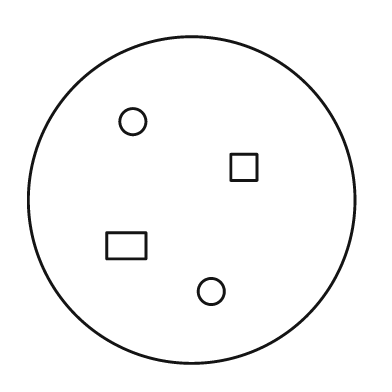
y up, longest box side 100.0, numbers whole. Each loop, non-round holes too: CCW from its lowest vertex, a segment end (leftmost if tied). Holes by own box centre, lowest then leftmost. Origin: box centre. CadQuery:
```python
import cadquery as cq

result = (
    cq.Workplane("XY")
    .moveTo(0.0, 0.0)
    .circle(50.0)
    .moveTo(6.0, -28.0)
    .circle(4.0)
    .moveTo(-26.0, -18.0)
    .lineTo(-14.0, -18.0)
    .lineTo(-14.0, -10.0)
    .lineTo(-26.0, -10.0)
    .close()
    .moveTo(12.0, 6.0)
    .lineTo(20.0, 6.0)
    .lineTo(20.0, 14.0)
    .lineTo(12.0, 14.0)
    .close()
    .moveTo(-18.0, 24.0)
    .circle(4.0)
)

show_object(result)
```